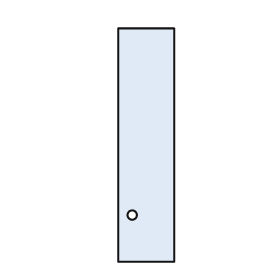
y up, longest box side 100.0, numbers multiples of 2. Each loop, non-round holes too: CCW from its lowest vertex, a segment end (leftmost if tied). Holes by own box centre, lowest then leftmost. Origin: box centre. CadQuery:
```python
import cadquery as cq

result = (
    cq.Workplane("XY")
    .moveTo(-12.0, -50.0)
    .lineTo(12.0, -50.0)
    .lineTo(12.0, 50.0)
    .lineTo(-12.0, 50.0)
    .close()
    .moveTo(-6.0, -30.0)
    .circle(2.0)
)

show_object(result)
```